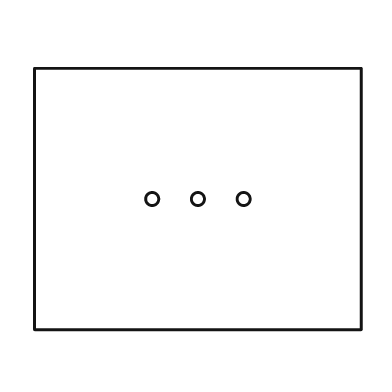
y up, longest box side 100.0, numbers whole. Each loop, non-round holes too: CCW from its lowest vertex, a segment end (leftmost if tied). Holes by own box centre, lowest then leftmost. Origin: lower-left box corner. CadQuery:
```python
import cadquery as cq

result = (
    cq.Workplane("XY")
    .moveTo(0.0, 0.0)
    .lineTo(100.0, 0.0)
    .lineTo(100.0, 80.0)
    .lineTo(0.0, 80.0)
    .close()
    .moveTo(36.0, 40.0)
    .circle(2.0)
    .moveTo(50.0, 40.0)
    .circle(2.0)
    .moveTo(64.0, 40.0)
    .circle(2.0)
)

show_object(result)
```